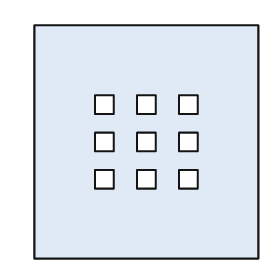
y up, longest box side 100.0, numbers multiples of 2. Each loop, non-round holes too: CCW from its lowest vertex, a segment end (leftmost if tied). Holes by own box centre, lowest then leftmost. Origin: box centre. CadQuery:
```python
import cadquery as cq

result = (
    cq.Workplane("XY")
    .moveTo(-48.0, -50.0)
    .lineTo(48.0, -50.0)
    .lineTo(48.0, 50.0)
    .lineTo(-48.0, 50.0)
    .close()
    .moveTo(-22.0, -20.0)
    .lineTo(-14.0, -20.0)
    .lineTo(-14.0, -12.0)
    .lineTo(-22.0, -12.0)
    .close()
    .moveTo(-4.0, -20.0)
    .lineTo(4.0, -20.0)
    .lineTo(4.0, -12.0)
    .lineTo(-4.0, -12.0)
    .close()
    .moveTo(14.0, -20.0)
    .lineTo(22.0, -20.0)
    .lineTo(22.0, -12.0)
    .lineTo(14.0, -12.0)
    .close()
    .moveTo(-22.0, -4.0)
    .lineTo(-14.0, -4.0)
    .lineTo(-14.0, 4.0)
    .lineTo(-22.0, 4.0)
    .close()
    .moveTo(-4.0, -4.0)
    .lineTo(4.0, -4.0)
    .lineTo(4.0, 4.0)
    .lineTo(-4.0, 4.0)
    .close()
    .moveTo(14.0, -4.0)
    .lineTo(22.0, -4.0)
    .lineTo(22.0, 4.0)
    .lineTo(14.0, 4.0)
    .close()
    .moveTo(-22.0, 12.0)
    .lineTo(-14.0, 12.0)
    .lineTo(-14.0, 20.0)
    .lineTo(-22.0, 20.0)
    .close()
    .moveTo(-4.0, 12.0)
    .lineTo(4.0, 12.0)
    .lineTo(4.0, 20.0)
    .lineTo(-4.0, 20.0)
    .close()
    .moveTo(14.0, 12.0)
    .lineTo(22.0, 12.0)
    .lineTo(22.0, 20.0)
    .lineTo(14.0, 20.0)
    .close()
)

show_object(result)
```